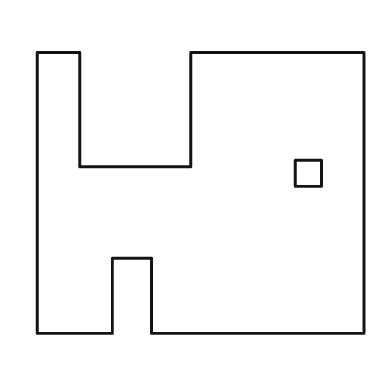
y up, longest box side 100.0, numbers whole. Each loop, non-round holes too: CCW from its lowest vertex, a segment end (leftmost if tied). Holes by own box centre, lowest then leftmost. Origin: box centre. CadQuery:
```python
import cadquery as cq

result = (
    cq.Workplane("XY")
    .moveTo(-50.0, -43.0)
    .lineTo(-27.0, -43.0)
    .lineTo(-27.0, -20.0)
    .lineTo(-15.0, -20.0)
    .lineTo(-15.0, -43.0)
    .lineTo(50.0, -43.0)
    .lineTo(50.0, 43.0)
    .lineTo(-3.0, 43.0)
    .lineTo(-3.0, 8.0)
    .lineTo(-37.0, 8.0)
    .lineTo(-37.0, 43.0)
    .lineTo(-50.0, 43.0)
    .close()
    .moveTo(29.0, 2.0)
    .lineTo(37.0, 2.0)
    .lineTo(37.0, 10.0)
    .lineTo(29.0, 10.0)
    .close()
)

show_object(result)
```